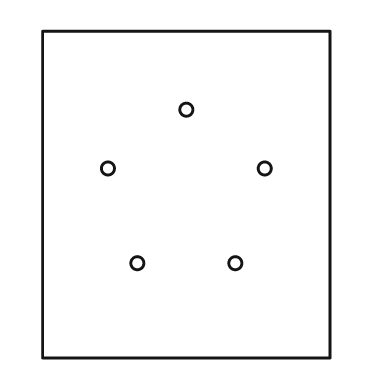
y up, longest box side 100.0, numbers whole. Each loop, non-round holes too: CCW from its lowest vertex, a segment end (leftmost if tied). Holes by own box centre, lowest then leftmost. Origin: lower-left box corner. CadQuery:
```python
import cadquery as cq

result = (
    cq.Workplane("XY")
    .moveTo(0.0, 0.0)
    .lineTo(88.0, 0.0)
    .lineTo(88.0, 100.0)
    .lineTo(0.0, 100.0)
    .close()
    .moveTo(29.0, 29.0)
    .circle(2.0)
    .moveTo(59.0, 29.0)
    .circle(2.0)
    .moveTo(20.0, 58.0)
    .circle(2.0)
    .moveTo(68.0, 58.0)
    .circle(2.0)
    .moveTo(44.0, 76.0)
    .circle(2.0)
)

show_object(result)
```